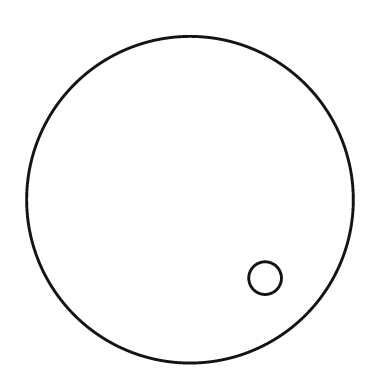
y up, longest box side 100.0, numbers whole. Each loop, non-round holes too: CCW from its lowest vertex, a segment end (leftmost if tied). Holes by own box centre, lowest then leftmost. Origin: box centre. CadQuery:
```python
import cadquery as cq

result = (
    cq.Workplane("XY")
    .moveTo(0.0, 0.0)
    .circle(50.0)
    .moveTo(23.0, -24.0)
    .circle(5.0)
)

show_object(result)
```